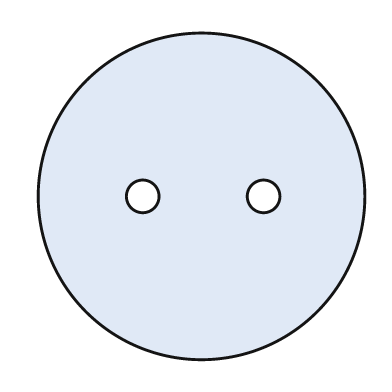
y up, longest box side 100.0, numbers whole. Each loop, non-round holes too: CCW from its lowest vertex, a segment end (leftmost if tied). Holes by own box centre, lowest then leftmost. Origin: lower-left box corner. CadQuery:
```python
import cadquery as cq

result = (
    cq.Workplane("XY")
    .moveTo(50.0, 50.0)
    .circle(50.0)
    .moveTo(32.0, 50.0)
    .circle(5.0)
    .moveTo(69.0, 50.0)
    .circle(5.0)
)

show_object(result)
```